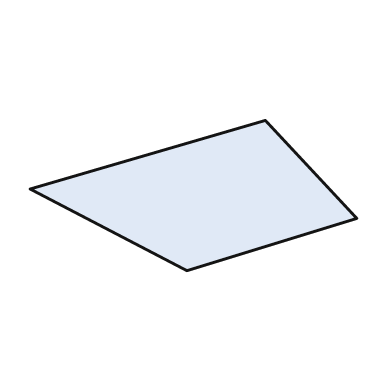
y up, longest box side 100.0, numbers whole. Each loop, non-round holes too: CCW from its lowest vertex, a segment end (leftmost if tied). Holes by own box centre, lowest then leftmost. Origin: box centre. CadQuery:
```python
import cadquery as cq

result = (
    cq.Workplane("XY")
    .moveTo(-2.0, -23.0)
    .lineTo(50.0, -7.0)
    .lineTo(22.0, 23.0)
    .lineTo(-50.0, 2.0)
    .close()
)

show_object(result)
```